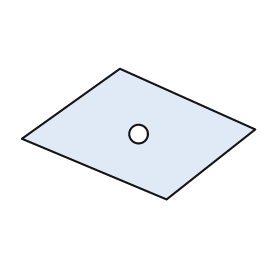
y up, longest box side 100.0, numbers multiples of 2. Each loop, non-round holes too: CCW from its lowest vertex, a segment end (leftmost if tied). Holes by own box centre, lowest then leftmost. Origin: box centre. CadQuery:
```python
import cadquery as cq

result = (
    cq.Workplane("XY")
    .moveTo(12.0, -28.0)
    .lineTo(50.0, 2.0)
    .lineTo(-8.0, 28.0)
    .lineTo(-50.0, -2.0)
    .close()
    .moveTo(0.0, 0.0)
    .circle(4.0)
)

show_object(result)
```